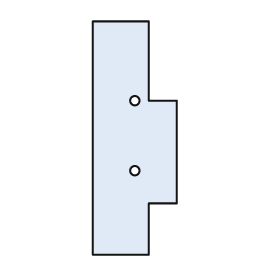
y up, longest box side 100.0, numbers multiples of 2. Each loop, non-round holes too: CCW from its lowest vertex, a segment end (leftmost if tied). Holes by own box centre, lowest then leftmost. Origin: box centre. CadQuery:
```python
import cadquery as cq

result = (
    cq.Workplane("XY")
    .moveTo(-18.0, -50.0)
    .lineTo(6.0, -50.0)
    .lineTo(6.0, -28.0)
    .lineTo(18.0, -28.0)
    .lineTo(18.0, 16.0)
    .lineTo(6.0, 16.0)
    .lineTo(6.0, 50.0)
    .lineTo(-18.0, 50.0)
    .close()
    .moveTo(0.0, -14.0)
    .circle(2.0)
    .moveTo(0.0, 16.0)
    .circle(2.0)
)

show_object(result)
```